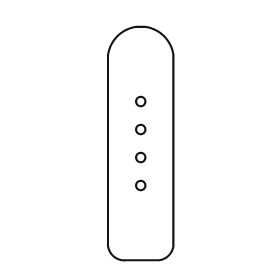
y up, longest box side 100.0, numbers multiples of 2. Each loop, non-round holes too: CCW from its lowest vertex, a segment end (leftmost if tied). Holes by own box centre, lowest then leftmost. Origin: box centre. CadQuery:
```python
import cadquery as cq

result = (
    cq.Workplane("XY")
    .moveTo(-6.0, -50.0)
    .lineTo(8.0, -50.0)
    .threePointArc((12.0, -48.0), (14.0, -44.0))
    .lineTo(14.0, 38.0)
    .threePointArc((10.0, 46.0), (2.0, 50.0))
    .lineTo(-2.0, 50.0)
    .threePointArc((-10.0, 46.0), (-14.0, 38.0))
    .lineTo(-14.0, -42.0)
    .threePointArc((-12.0, -48.0), (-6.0, -50.0))
    .close()
    .moveTo(0.0, -18.0)
    .circle(2.0)
    .moveTo(0.0, -6.0)
    .circle(2.0)
    .moveTo(0.0, 6.0)
    .circle(2.0)
    .moveTo(0.0, 18.0)
    .circle(2.0)
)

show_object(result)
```